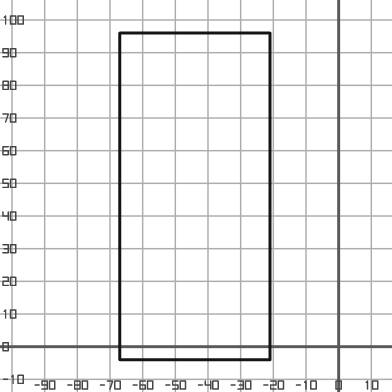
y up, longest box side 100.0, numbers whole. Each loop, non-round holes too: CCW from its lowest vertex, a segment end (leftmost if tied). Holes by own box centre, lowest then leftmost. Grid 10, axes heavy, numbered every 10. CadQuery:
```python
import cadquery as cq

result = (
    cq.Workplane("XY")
    .moveTo(-67.0, -4.0)
    .lineTo(-21.0, -4.0)
    .lineTo(-21.0, 96.0)
    .lineTo(-67.0, 96.0)
    .close()
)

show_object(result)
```